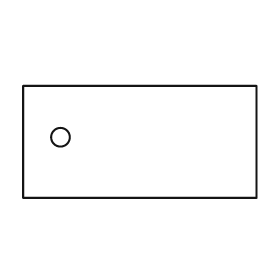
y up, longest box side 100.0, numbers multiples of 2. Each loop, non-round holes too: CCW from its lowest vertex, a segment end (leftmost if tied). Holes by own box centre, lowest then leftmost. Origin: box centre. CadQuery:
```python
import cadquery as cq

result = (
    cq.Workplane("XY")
    .moveTo(-50.0, -24.0)
    .lineTo(50.0, -24.0)
    .lineTo(50.0, 24.0)
    .lineTo(-50.0, 24.0)
    .close()
    .moveTo(-34.0, 2.0)
    .circle(4.0)
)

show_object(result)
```